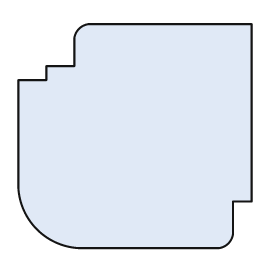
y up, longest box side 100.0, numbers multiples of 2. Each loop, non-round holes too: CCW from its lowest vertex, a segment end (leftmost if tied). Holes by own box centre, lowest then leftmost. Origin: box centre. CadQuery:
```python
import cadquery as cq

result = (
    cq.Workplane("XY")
    .moveTo(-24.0, -48.0)
    .lineTo(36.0, -48.0)
    .threePointArc((40.0, -46.0), (42.0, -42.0))
    .lineTo(42.0, -28.0)
    .lineTo(50.0, -28.0)
    .lineTo(50.0, 48.0)
    .lineTo(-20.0, 48.0)
    .threePointArc((-24.0, 46.0), (-26.0, 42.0))
    .lineTo(-26.0, 30.0)
    .lineTo(-38.0, 30.0)
    .lineTo(-38.0, 24.0)
    .lineTo(-50.0, 24.0)
    .lineTo(-50.0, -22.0)
    .threePointArc((-42.0, -40.0), (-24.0, -48.0))
    .close()
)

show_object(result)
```